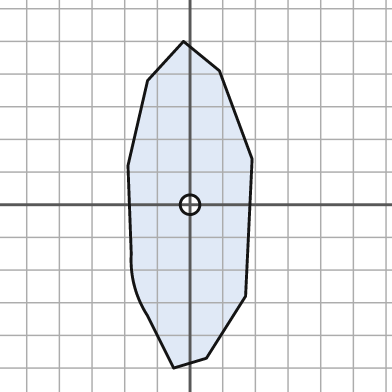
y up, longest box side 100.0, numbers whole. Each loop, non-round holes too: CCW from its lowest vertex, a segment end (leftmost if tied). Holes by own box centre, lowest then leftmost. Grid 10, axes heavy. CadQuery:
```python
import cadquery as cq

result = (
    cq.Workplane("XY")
    .moveTo(-5.0, -50.0)
    .lineTo(5.0, -47.0)
    .lineTo(17.0, -28.0)
    .lineTo(19.0, 14.0)
    .lineTo(9.0, 41.0)
    .lineTo(-2.0, 50.0)
    .lineTo(-13.0, 38.0)
    .lineTo(-19.0, 12.0)
    .lineTo(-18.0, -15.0)
    .threePointArc((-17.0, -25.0), (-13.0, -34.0))
    .close()
    .moveTo(0.0, 0.0)
    .circle(3.0)
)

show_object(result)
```